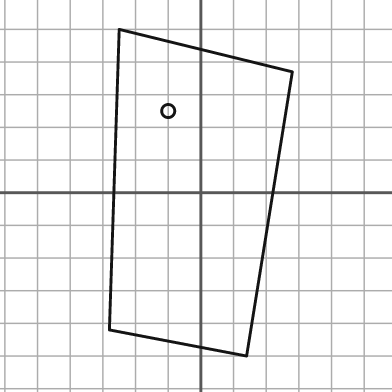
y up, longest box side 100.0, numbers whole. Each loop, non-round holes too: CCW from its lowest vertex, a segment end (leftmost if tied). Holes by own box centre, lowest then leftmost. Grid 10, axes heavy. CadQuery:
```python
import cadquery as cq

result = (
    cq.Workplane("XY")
    .moveTo(14.0, -50.0)
    .lineTo(28.0, 37.0)
    .lineTo(-25.0, 50.0)
    .lineTo(-28.0, -42.0)
    .close()
    .moveTo(-10.0, 25.0)
    .circle(2.0)
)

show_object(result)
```